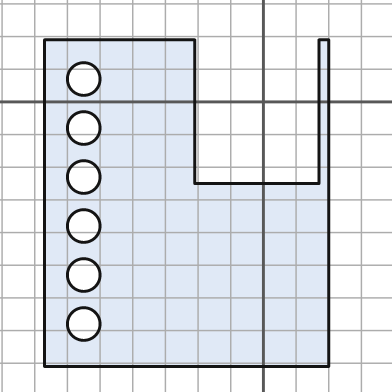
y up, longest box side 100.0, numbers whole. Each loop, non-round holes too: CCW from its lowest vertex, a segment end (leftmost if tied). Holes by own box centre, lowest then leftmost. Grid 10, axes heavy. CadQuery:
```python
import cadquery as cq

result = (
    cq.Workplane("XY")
    .moveTo(-67.0, -81.0)
    .lineTo(20.0, -81.0)
    .lineTo(20.0, 19.0)
    .lineTo(17.0, 19.0)
    .lineTo(17.0, -25.0)
    .lineTo(-21.0, -25.0)
    .lineTo(-21.0, 19.0)
    .lineTo(-67.0, 19.0)
    .close()
    .moveTo(-55.0, -68.0)
    .circle(5.0)
    .moveTo(-55.0, -53.0)
    .circle(5.0)
    .moveTo(-55.0, -38.0)
    .circle(5.0)
    .moveTo(-55.0, -23.0)
    .circle(5.0)
    .moveTo(-55.0, -8.0)
    .circle(5.0)
    .moveTo(-55.0, 7.0)
    .circle(5.0)
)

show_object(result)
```